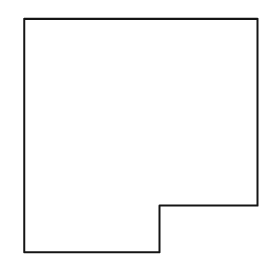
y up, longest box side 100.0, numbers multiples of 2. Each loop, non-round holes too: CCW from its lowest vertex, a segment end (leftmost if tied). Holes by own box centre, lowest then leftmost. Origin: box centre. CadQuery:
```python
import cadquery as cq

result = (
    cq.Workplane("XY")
    .moveTo(-50.0, -50.0)
    .lineTo(8.0, -50.0)
    .lineTo(8.0, -30.0)
    .lineTo(50.0, -30.0)
    .lineTo(50.0, 50.0)
    .lineTo(-50.0, 50.0)
    .close()
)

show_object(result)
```